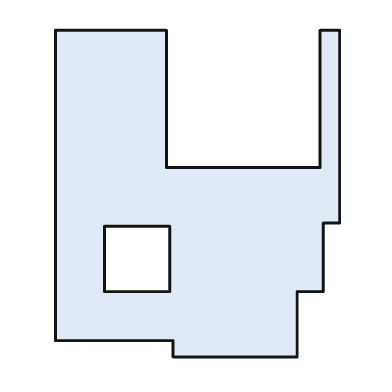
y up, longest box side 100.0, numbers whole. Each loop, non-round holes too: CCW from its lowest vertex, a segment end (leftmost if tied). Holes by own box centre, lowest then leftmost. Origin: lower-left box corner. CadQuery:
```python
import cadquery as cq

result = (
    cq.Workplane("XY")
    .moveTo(36.0, 0.0)
    .lineTo(74.0, 0.0)
    .lineTo(74.0, 20.0)
    .lineTo(82.0, 20.0)
    .lineTo(82.0, 41.0)
    .lineTo(87.0, 41.0)
    .lineTo(87.0, 100.0)
    .lineTo(81.0, 100.0)
    .lineTo(81.0, 58.0)
    .lineTo(34.0, 58.0)
    .lineTo(34.0, 100.0)
    .lineTo(0.0, 100.0)
    .lineTo(0.0, 5.0)
    .lineTo(36.0, 5.0)
    .close()
    .moveTo(15.0, 20.0)
    .lineTo(35.0, 20.0)
    .lineTo(35.0, 40.0)
    .lineTo(15.0, 40.0)
    .close()
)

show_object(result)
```